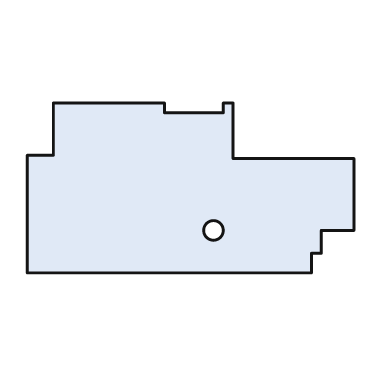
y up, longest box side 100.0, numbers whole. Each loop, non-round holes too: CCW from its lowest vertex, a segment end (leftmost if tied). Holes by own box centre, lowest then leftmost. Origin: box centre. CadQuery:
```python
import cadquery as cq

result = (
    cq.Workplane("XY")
    .moveTo(-50.0, -26.0)
    .lineTo(37.0, -26.0)
    .lineTo(37.0, -20.0)
    .lineTo(40.0, -20.0)
    .lineTo(40.0, -13.0)
    .lineTo(50.0, -13.0)
    .lineTo(50.0, 9.0)
    .lineTo(13.0, 9.0)
    .lineTo(13.0, 26.0)
    .lineTo(10.0, 26.0)
    .lineTo(10.0, 23.0)
    .lineTo(-8.0, 23.0)
    .lineTo(-8.0, 26.0)
    .lineTo(-42.0, 26.0)
    .lineTo(-42.0, 10.0)
    .lineTo(-50.0, 10.0)
    .close()
    .moveTo(7.0, -13.0)
    .circle(3.0)
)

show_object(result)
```